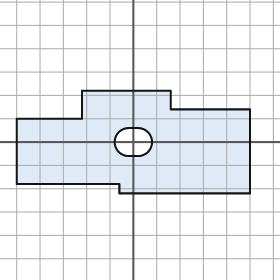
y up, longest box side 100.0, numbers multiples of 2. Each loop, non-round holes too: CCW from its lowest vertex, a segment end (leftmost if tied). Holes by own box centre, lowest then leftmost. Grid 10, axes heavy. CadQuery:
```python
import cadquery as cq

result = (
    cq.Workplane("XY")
    .moveTo(-6.0, -22.0)
    .lineTo(50.0, -22.0)
    .lineTo(50.0, 14.0)
    .lineTo(16.0, 14.0)
    .lineTo(16.0, 22.0)
    .lineTo(-22.0, 22.0)
    .lineTo(-22.0, 10.0)
    .lineTo(-50.0, 10.0)
    .lineTo(-50.0, -18.0)
    .lineTo(-6.0, -18.0)
    .close()
    .moveTo(-2.0, -6.0)
    .lineTo(2.0, -6.0)
    .threePointArc((8.0, 0.0), (2.0, 6.0))
    .lineTo(-2.0, 6.0)
    .threePointArc((-8.0, 0.0), (-2.0, -6.0))
    .close()
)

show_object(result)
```